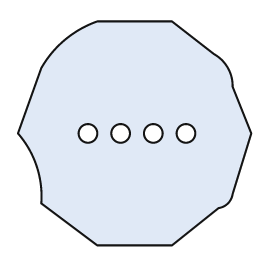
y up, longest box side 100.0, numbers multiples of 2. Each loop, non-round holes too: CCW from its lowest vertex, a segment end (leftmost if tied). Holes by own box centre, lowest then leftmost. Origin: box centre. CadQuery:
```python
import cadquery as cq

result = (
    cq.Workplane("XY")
    .moveTo(-16.0, -48.0)
    .lineTo(16.0, -48.0)
    .lineTo(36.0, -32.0)
    .threePointArc((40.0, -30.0), (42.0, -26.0))
    .lineTo(50.0, 0.0)
    .lineTo(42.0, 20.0)
    .threePointArc((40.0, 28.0), (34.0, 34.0))
    .lineTo(16.0, 48.0)
    .lineTo(-16.0, 48.0)
    .threePointArc((-30.0, 40.0), (-40.0, 28.0))
    .lineTo(-50.0, 0.0)
    .threePointArc((-42.0, -14.0), (-40.0, -30.0))
    .close()
    .moveTo(-20.0, 0.0)
    .circle(4.0)
    .moveTo(-6.0, 0.0)
    .circle(4.0)
    .moveTo(8.0, 0.0)
    .circle(4.0)
    .moveTo(22.0, 0.0)
    .circle(4.0)
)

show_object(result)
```